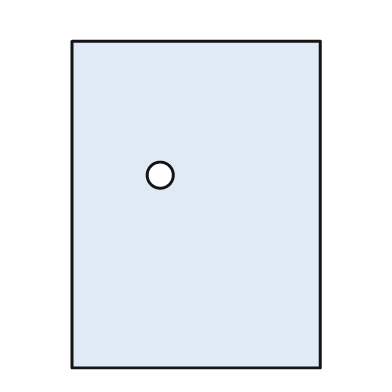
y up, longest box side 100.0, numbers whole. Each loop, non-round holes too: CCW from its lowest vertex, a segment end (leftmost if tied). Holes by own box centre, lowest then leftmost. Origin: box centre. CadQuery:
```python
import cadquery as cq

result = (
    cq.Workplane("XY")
    .moveTo(-38.0, -50.0)
    .lineTo(38.0, -50.0)
    .lineTo(38.0, 50.0)
    .lineTo(-38.0, 50.0)
    .close()
    .moveTo(-11.0, 9.0)
    .circle(4.0)
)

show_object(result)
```